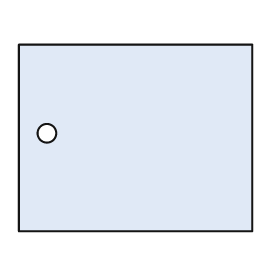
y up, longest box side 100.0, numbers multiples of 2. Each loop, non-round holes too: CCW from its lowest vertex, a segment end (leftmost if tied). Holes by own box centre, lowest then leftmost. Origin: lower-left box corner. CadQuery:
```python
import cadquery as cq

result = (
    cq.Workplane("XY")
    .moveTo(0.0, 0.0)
    .lineTo(100.0, 0.0)
    .lineTo(100.0, 80.0)
    .lineTo(0.0, 80.0)
    .close()
    .moveTo(12.0, 42.0)
    .circle(4.0)
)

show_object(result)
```